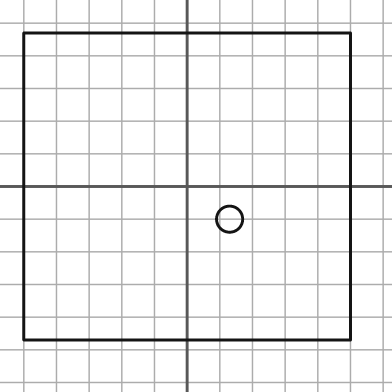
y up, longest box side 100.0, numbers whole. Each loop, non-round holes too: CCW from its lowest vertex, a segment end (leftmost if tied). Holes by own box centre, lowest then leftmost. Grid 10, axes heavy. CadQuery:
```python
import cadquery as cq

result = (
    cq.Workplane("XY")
    .moveTo(-50.0, -47.0)
    .lineTo(50.0, -47.0)
    .lineTo(50.0, 47.0)
    .lineTo(-50.0, 47.0)
    .close()
    .moveTo(13.0, -10.0)
    .circle(4.0)
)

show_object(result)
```